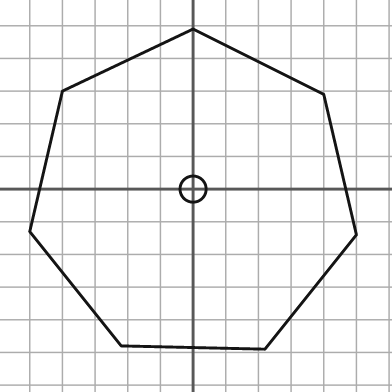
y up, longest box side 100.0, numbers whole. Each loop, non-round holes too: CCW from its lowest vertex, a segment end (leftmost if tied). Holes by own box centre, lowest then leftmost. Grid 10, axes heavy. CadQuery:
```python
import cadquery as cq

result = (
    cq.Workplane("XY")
    .moveTo(22.0, -49.0)
    .lineTo(50.0, -14.0)
    .lineTo(40.0, 29.0)
    .lineTo(0.0, 49.0)
    .lineTo(-40.0, 30.0)
    .lineTo(-50.0, -13.0)
    .lineTo(-22.0, -48.0)
    .close()
    .moveTo(0.0, 0.0)
    .circle(4.0)
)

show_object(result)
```